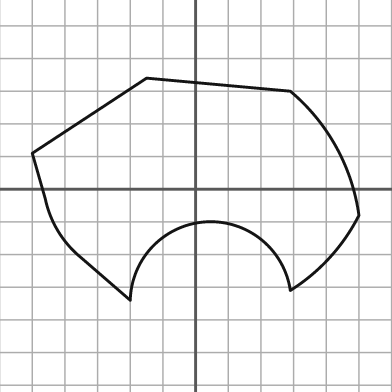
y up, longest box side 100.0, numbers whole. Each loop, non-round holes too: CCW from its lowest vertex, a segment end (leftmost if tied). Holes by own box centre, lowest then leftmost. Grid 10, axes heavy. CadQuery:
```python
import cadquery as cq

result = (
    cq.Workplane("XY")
    .moveTo(-20.0, -34.0)
    .threePointArc((3.0, -10.0), (29.0, -31.0))
    .threePointArc((41.0, -21.0), (50.0, -8.0))
    .threePointArc((43.0, 13.0), (29.0, 30.0))
    .lineTo(-15.0, 34.0)
    .lineTo(-50.0, 11.0)
    .lineTo(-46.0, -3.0)
    .threePointArc((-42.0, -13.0), (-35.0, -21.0))
    .close()
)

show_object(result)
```